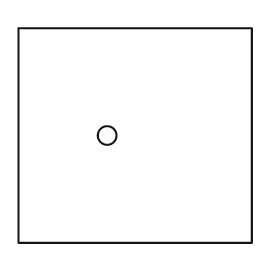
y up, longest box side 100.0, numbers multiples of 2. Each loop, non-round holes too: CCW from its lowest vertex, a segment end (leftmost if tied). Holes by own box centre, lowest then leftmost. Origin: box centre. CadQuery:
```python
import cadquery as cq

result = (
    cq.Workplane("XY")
    .moveTo(-50.0, -46.0)
    .lineTo(50.0, -46.0)
    .lineTo(50.0, 46.0)
    .lineTo(-50.0, 46.0)
    .close()
    .moveTo(-12.0, 0.0)
    .circle(4.0)
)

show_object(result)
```